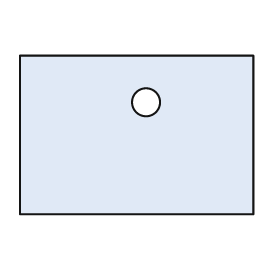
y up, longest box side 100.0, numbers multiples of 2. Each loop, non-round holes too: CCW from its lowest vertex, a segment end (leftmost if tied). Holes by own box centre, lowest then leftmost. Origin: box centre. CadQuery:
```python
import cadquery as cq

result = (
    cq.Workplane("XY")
    .moveTo(-50.0, -34.0)
    .lineTo(50.0, -34.0)
    .lineTo(50.0, 34.0)
    .lineTo(-50.0, 34.0)
    .close()
    .moveTo(4.0, 14.0)
    .circle(6.0)
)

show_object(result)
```